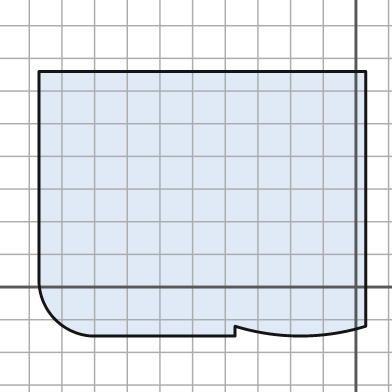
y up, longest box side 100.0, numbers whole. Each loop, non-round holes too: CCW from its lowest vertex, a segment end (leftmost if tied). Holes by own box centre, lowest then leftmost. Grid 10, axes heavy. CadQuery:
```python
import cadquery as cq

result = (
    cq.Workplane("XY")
    .moveTo(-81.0, -15.0)
    .lineTo(-37.0, -15.0)
    .lineTo(-37.0, -12.0)
    .threePointArc((-17.0, -15.0), (3.0, -12.0))
    .lineTo(3.0, 66.0)
    .lineTo(-97.0, 66.0)
    .lineTo(-97.0, 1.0)
    .threePointArc((-92.0, -10.0), (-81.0, -15.0))
    .close()
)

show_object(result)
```